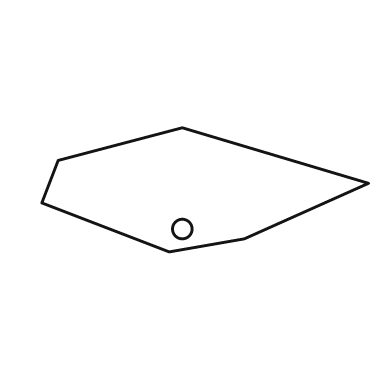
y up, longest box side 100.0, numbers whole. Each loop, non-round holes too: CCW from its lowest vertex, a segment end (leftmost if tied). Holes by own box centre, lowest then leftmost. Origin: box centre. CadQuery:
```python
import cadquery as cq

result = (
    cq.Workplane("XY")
    .moveTo(-11.0, -19.0)
    .lineTo(12.0, -15.0)
    .lineTo(50.0, 2.0)
    .lineTo(-7.0, 19.0)
    .lineTo(-45.0, 9.0)
    .lineTo(-50.0, -4.0)
    .close()
    .moveTo(-7.0, -12.0)
    .circle(3.0)
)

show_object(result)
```